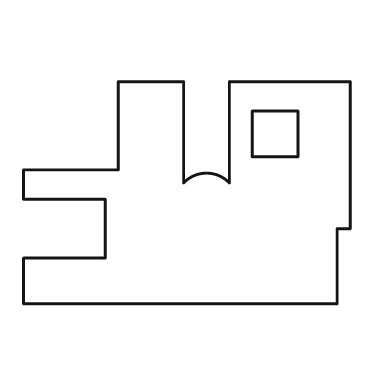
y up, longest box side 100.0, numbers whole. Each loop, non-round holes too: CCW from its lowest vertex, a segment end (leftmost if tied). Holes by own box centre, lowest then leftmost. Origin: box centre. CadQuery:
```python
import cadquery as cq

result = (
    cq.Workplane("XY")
    .moveTo(-50.0, -34.0)
    .lineTo(46.0, -34.0)
    .lineTo(46.0, -11.0)
    .lineTo(50.0, -11.0)
    .lineTo(50.0, 34.0)
    .lineTo(13.0, 34.0)
    .lineTo(13.0, 3.0)
    .threePointArc((6.0, 6.0), (-1.0, 3.0))
    .lineTo(-1.0, 34.0)
    .lineTo(-21.0, 34.0)
    .lineTo(-21.0, 7.0)
    .lineTo(-50.0, 7.0)
    .lineTo(-50.0, -2.0)
    .lineTo(-25.0, -2.0)
    .lineTo(-25.0, -20.0)
    .lineTo(-50.0, -20.0)
    .close()
    .moveTo(20.0, 11.0)
    .lineTo(34.0, 11.0)
    .lineTo(34.0, 25.0)
    .lineTo(20.0, 25.0)
    .close()
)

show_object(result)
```